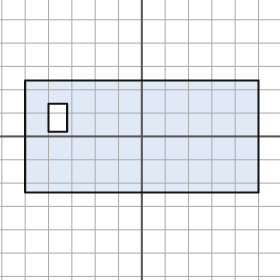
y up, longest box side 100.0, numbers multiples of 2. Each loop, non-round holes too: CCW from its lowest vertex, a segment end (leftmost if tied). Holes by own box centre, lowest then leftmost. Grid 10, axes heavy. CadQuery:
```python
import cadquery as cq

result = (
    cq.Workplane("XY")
    .moveTo(-50.0, -24.0)
    .lineTo(50.0, -24.0)
    .lineTo(50.0, 24.0)
    .lineTo(-50.0, 24.0)
    .close()
    .moveTo(-40.0, 2.0)
    .lineTo(-32.0, 2.0)
    .lineTo(-32.0, 14.0)
    .lineTo(-40.0, 14.0)
    .close()
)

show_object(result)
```